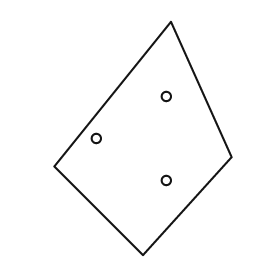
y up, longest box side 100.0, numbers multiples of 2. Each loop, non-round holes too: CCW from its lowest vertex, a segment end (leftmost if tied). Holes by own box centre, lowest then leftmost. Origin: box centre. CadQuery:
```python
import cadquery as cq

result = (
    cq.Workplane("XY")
    .moveTo(0.0, -50.0)
    .lineTo(38.0, -8.0)
    .lineTo(12.0, 50.0)
    .lineTo(-38.0, -12.0)
    .close()
    .moveTo(10.0, -18.0)
    .circle(2.0)
    .moveTo(-20.0, 0.0)
    .circle(2.0)
    .moveTo(10.0, 18.0)
    .circle(2.0)
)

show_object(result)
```